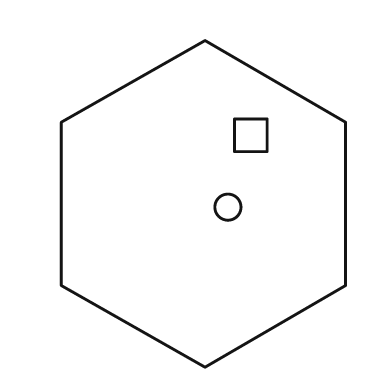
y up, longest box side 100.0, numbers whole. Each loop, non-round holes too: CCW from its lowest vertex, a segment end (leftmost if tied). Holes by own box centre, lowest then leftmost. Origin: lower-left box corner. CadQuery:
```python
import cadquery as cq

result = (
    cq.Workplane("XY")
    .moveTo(44.0, 0.0)
    .lineTo(87.0, 25.0)
    .lineTo(87.0, 75.0)
    .lineTo(44.0, 100.0)
    .lineTo(0.0, 75.0)
    .lineTo(0.0, 25.0)
    .close()
    .moveTo(51.0, 49.0)
    .circle(4.0)
    .moveTo(53.0, 66.0)
    .lineTo(63.0, 66.0)
    .lineTo(63.0, 76.0)
    .lineTo(53.0, 76.0)
    .close()
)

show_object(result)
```